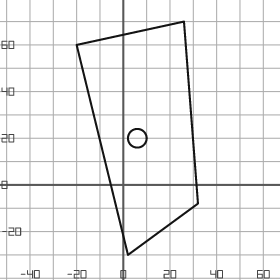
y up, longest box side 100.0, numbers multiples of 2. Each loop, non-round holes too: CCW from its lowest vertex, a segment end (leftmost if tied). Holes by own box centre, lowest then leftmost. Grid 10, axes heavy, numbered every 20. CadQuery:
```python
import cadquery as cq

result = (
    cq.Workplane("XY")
    .moveTo(2.0, -30.0)
    .lineTo(32.0, -8.0)
    .lineTo(26.0, 70.0)
    .lineTo(-20.0, 60.0)
    .close()
    .moveTo(6.0, 20.0)
    .circle(4.0)
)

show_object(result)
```